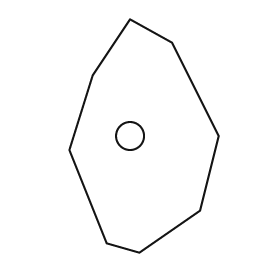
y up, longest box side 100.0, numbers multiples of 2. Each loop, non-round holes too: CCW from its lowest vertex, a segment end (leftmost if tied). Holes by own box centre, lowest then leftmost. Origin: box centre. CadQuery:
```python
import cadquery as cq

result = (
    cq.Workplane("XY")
    .moveTo(-2.0, -50.0)
    .lineTo(24.0, -32.0)
    .lineTo(32.0, 0.0)
    .lineTo(12.0, 40.0)
    .lineTo(-6.0, 50.0)
    .lineTo(-22.0, 26.0)
    .lineTo(-32.0, -6.0)
    .lineTo(-16.0, -46.0)
    .close()
    .moveTo(-6.0, 0.0)
    .circle(6.0)
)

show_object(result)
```